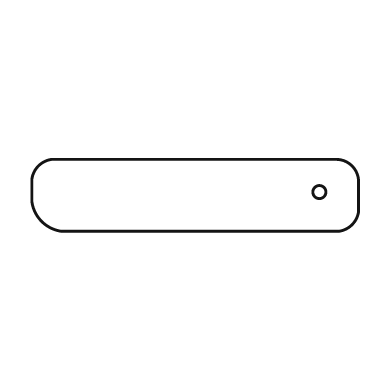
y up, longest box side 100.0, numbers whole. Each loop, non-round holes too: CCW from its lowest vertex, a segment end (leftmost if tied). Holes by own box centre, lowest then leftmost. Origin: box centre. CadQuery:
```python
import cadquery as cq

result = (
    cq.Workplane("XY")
    .moveTo(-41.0, -11.0)
    .lineTo(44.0, -11.0)
    .threePointArc((48.0, -9.0), (50.0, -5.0))
    .lineTo(50.0, 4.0)
    .threePointArc((48.0, 9.0), (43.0, 11.0))
    .lineTo(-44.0, 11.0)
    .threePointArc((-48.0, 9.0), (-50.0, 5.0))
    .lineTo(-50.0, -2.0)
    .threePointArc((-47.0, -8.0), (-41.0, -11.0))
    .close()
    .moveTo(38.0, 1.0)
    .circle(2.0)
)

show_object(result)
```